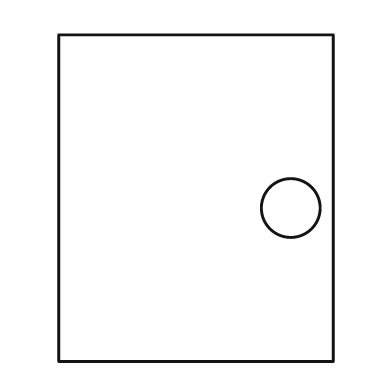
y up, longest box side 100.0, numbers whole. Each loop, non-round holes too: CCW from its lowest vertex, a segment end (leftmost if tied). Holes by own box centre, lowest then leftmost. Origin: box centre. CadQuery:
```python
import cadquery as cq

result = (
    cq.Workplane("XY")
    .moveTo(-42.0, -50.0)
    .lineTo(42.0, -50.0)
    .lineTo(42.0, 50.0)
    .lineTo(-42.0, 50.0)
    .close()
    .moveTo(29.0, -3.0)
    .circle(9.0)
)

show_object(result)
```